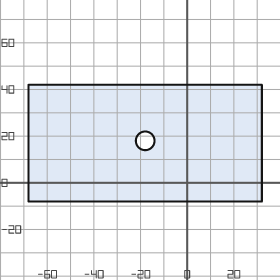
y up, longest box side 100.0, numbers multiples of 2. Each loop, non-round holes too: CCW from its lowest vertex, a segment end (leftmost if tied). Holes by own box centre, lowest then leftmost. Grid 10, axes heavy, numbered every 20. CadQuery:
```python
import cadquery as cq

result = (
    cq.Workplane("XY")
    .moveTo(-68.0, -8.0)
    .lineTo(32.0, -8.0)
    .lineTo(32.0, 42.0)
    .lineTo(-68.0, 42.0)
    .close()
    .moveTo(-18.0, 18.0)
    .circle(4.0)
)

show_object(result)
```